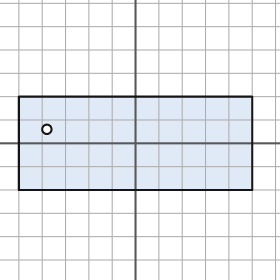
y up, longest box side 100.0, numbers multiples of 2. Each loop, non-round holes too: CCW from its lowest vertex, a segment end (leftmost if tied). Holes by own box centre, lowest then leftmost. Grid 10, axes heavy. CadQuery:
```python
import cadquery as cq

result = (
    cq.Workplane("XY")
    .moveTo(-50.0, -20.0)
    .lineTo(50.0, -20.0)
    .lineTo(50.0, 20.0)
    .lineTo(-50.0, 20.0)
    .close()
    .moveTo(-38.0, 6.0)
    .circle(2.0)
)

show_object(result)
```